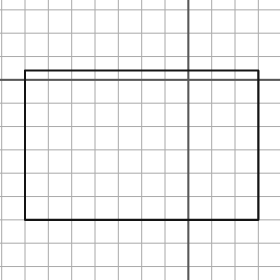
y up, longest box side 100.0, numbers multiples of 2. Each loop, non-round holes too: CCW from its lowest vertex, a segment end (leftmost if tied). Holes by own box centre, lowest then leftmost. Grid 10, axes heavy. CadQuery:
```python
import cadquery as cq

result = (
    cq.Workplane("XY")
    .moveTo(-70.0, -60.0)
    .lineTo(30.0, -60.0)
    .lineTo(30.0, 4.0)
    .lineTo(-70.0, 4.0)
    .close()
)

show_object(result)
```